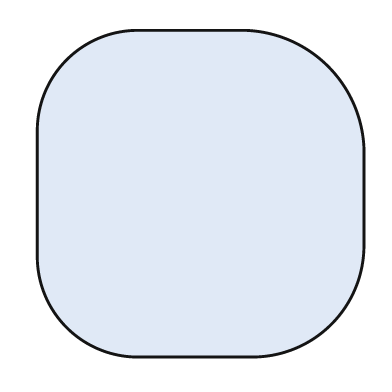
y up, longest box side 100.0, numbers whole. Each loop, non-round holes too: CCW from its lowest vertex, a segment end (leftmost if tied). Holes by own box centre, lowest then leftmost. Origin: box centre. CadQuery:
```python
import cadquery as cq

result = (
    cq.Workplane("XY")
    .moveTo(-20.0, -50.0)
    .lineTo(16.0, -50.0)
    .threePointArc((40.0, -40.0), (50.0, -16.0))
    .lineTo(50.0, 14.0)
    .threePointArc((39.0, 39.0), (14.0, 50.0))
    .lineTo(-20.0, 50.0)
    .threePointArc((-41.0, 41.0), (-50.0, 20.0))
    .lineTo(-50.0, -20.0)
    .threePointArc((-41.0, -41.0), (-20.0, -50.0))
    .close()
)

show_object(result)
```